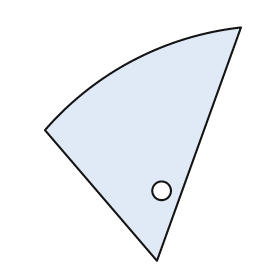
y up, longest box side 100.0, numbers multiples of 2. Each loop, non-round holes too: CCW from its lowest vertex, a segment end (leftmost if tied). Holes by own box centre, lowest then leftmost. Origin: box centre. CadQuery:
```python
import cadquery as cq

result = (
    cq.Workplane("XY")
    .moveTo(6.0, -50.0)
    .lineTo(42.0, 50.0)
    .threePointArc((-4.0, 36.0), (-42.0, 6.0))
    .close()
    .moveTo(8.0, -20.0)
    .circle(4.0)
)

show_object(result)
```